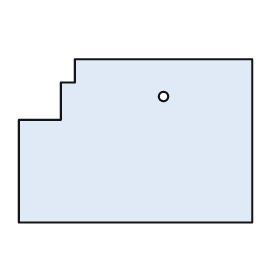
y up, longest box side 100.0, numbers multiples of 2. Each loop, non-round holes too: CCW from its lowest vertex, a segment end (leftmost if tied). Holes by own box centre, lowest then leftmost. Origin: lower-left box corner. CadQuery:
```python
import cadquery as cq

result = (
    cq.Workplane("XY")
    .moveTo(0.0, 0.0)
    .lineTo(100.0, 0.0)
    .lineTo(100.0, 70.0)
    .lineTo(24.0, 70.0)
    .lineTo(24.0, 60.0)
    .lineTo(18.0, 60.0)
    .lineTo(18.0, 44.0)
    .lineTo(0.0, 44.0)
    .close()
    .moveTo(62.0, 54.0)
    .circle(2.0)
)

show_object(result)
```